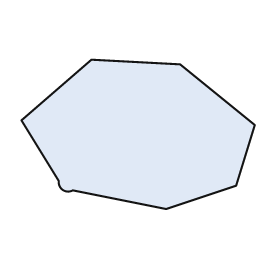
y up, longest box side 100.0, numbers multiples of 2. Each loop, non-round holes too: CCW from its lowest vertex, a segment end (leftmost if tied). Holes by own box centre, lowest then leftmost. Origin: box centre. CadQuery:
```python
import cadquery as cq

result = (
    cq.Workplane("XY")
    .moveTo(12.0, -32.0)
    .lineTo(42.0, -22.0)
    .lineTo(50.0, 4.0)
    .lineTo(18.0, 30.0)
    .lineTo(-20.0, 32.0)
    .lineTo(-50.0, 6.0)
    .lineTo(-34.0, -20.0)
    .threePointArc((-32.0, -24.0), (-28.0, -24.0))
    .close()
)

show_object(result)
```